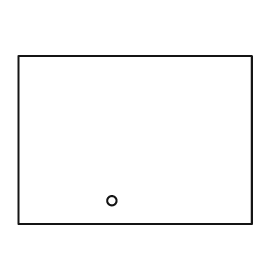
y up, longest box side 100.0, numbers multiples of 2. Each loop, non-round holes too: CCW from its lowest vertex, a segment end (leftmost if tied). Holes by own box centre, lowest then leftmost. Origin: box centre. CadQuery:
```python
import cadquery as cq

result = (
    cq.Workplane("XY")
    .moveTo(-50.0, -36.0)
    .lineTo(50.0, -36.0)
    .lineTo(50.0, 36.0)
    .lineTo(-50.0, 36.0)
    .close()
    .moveTo(-10.0, -26.0)
    .circle(2.0)
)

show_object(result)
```